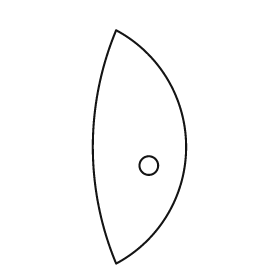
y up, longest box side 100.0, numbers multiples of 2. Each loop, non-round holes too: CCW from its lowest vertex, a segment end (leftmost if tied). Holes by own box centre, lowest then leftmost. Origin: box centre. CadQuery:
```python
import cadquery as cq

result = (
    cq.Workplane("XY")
    .moveTo(-10.0, -50.0)
    .threePointArc((20.0, 0.0), (-10.0, 50.0))
    .threePointArc((-20.0, 0.0), (-10.0, -50.0))
    .close()
    .moveTo(4.0, -8.0)
    .circle(4.0)
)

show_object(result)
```